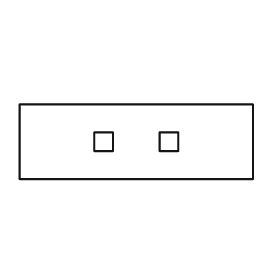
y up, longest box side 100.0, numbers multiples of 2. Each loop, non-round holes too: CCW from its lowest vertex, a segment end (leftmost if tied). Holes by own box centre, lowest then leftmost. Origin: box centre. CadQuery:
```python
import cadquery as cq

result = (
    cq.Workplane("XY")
    .moveTo(-50.0, -16.0)
    .lineTo(50.0, -16.0)
    .lineTo(50.0, 16.0)
    .lineTo(-50.0, 16.0)
    .close()
    .moveTo(-18.0, -4.0)
    .lineTo(-10.0, -4.0)
    .lineTo(-10.0, 4.0)
    .lineTo(-18.0, 4.0)
    .close()
    .moveTo(10.0, -4.0)
    .lineTo(18.0, -4.0)
    .lineTo(18.0, 4.0)
    .lineTo(10.0, 4.0)
    .close()
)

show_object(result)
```